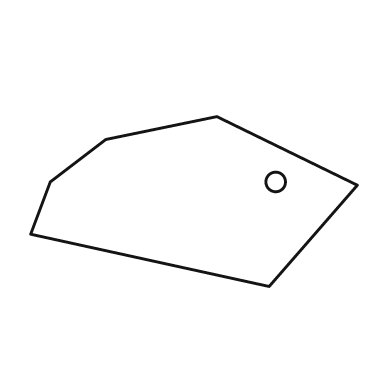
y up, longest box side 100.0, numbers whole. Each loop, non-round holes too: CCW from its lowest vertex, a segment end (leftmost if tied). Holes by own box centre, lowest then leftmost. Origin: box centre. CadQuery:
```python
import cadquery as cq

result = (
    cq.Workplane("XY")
    .moveTo(23.0, -26.0)
    .lineTo(50.0, 5.0)
    .lineTo(7.0, 26.0)
    .lineTo(-27.0, 19.0)
    .lineTo(-44.0, 6.0)
    .lineTo(-50.0, -10.0)
    .close()
    .moveTo(25.0, 6.0)
    .circle(3.0)
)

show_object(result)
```